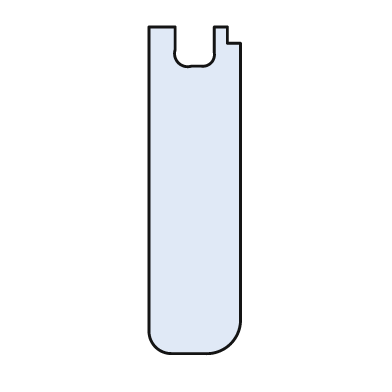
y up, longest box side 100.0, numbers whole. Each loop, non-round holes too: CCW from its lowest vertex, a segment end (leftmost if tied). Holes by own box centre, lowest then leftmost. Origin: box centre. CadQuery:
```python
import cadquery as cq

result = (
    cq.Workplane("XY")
    .moveTo(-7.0, -50.0)
    .lineTo(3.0, -50.0)
    .threePointArc((11.0, -47.0), (14.0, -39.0))
    .lineTo(14.0, 45.0)
    .lineTo(10.0, 45.0)
    .lineTo(10.0, 50.0)
    .lineTo(6.0, 50.0)
    .lineTo(6.0, 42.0)
    .threePointArc((5.0, 39.0), (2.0, 38.0))
    .lineTo(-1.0, 38.0)
    .threePointArc((-5.0, 39.0), (-6.0, 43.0))
    .lineTo(-6.0, 50.0)
    .lineTo(-14.0, 50.0)
    .lineTo(-14.0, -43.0)
    .threePointArc((-12.0, -48.0), (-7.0, -50.0))
    .close()
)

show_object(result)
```